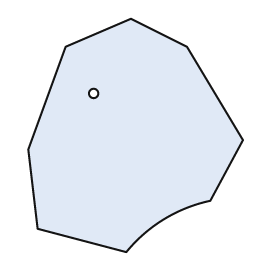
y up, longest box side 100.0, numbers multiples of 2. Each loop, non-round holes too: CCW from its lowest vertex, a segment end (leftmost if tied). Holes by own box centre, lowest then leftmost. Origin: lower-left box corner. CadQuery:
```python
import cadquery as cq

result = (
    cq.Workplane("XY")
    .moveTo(42.0, 0.0)
    .threePointArc((58.0, 14.0), (78.0, 22.0))
    .lineTo(92.0, 48.0)
    .lineTo(68.0, 88.0)
    .lineTo(44.0, 100.0)
    .lineTo(16.0, 88.0)
    .lineTo(0.0, 44.0)
    .lineTo(4.0, 10.0)
    .close()
    .moveTo(28.0, 68.0)
    .circle(2.0)
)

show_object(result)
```